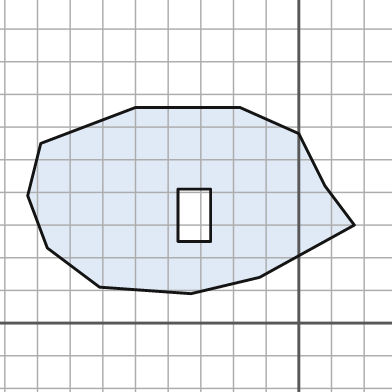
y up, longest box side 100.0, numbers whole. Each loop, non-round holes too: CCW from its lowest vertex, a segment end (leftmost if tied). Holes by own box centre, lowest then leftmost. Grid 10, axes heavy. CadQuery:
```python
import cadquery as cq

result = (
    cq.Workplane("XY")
    .moveTo(-33.0, 9.0)
    .lineTo(-12.0, 14.0)
    .lineTo(17.0, 30.0)
    .lineTo(8.0, 42.0)
    .lineTo(0.0, 58.0)
    .lineTo(-18.0, 66.0)
    .lineTo(-50.0, 66.0)
    .lineTo(-79.0, 55.0)
    .lineTo(-83.0, 39.0)
    .lineTo(-77.0, 23.0)
    .lineTo(-61.0, 11.0)
    .close()
    .moveTo(-37.0, 25.0)
    .lineTo(-27.0, 25.0)
    .lineTo(-27.0, 41.0)
    .lineTo(-37.0, 41.0)
    .close()
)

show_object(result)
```